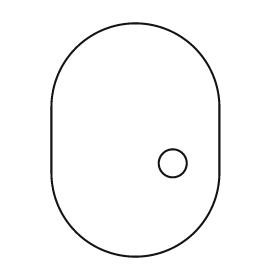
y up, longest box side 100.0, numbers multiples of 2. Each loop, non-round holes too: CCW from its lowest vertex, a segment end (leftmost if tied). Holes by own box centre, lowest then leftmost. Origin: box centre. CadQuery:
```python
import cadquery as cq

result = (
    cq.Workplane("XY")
    .moveTo(-36.0, -14.0)
    .threePointArc((0.0, -50.0), (36.0, -14.0))
    .lineTo(36.0, 14.0)
    .threePointArc((0.0, 50.0), (-36.0, 14.0))
    .close()
    .moveTo(16.0, -10.0)
    .circle(6.0)
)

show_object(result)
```